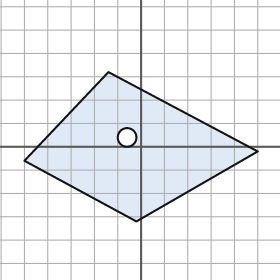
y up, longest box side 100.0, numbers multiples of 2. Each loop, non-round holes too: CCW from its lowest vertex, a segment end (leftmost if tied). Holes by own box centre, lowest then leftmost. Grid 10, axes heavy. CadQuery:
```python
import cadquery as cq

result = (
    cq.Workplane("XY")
    .moveTo(-2.0, -32.0)
    .lineTo(50.0, -2.0)
    .lineTo(-14.0, 32.0)
    .lineTo(-50.0, -6.0)
    .close()
    .moveTo(-6.0, 4.0)
    .circle(4.0)
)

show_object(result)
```